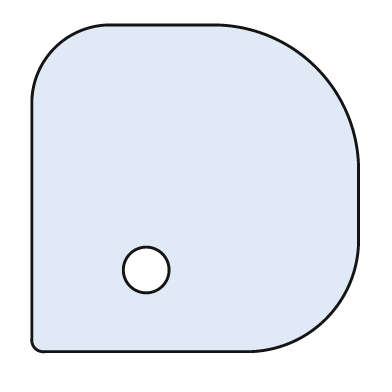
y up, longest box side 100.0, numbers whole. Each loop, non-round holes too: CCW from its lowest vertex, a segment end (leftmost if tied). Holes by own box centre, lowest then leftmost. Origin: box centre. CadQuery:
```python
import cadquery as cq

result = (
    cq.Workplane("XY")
    .moveTo(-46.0, -50.0)
    .lineTo(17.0, -50.0)
    .threePointArc((40.0, -40.0), (50.0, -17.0))
    .lineTo(50.0, 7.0)
    .threePointArc((37.0, 37.0), (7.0, 50.0))
    .lineTo(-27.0, 50.0)
    .threePointArc((-43.0, 43.0), (-50.0, 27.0))
    .lineTo(-50.0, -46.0)
    .threePointArc((-49.0, -49.0), (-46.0, -50.0))
    .close()
    .moveTo(-15.0, -25.0)
    .circle(7.0)
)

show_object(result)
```